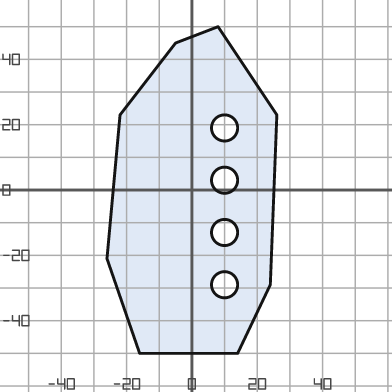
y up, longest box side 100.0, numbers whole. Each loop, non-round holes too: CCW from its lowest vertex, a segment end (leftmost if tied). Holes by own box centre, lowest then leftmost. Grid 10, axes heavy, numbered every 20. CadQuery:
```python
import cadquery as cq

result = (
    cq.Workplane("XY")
    .moveTo(-16.0, -50.0)
    .lineTo(14.0, -50.0)
    .lineTo(24.0, -29.0)
    .lineTo(26.0, 23.0)
    .lineTo(8.0, 50.0)
    .lineTo(-5.0, 45.0)
    .lineTo(-22.0, 23.0)
    .lineTo(-26.0, -21.0)
    .close()
    .moveTo(10.0, -29.0)
    .circle(4.0)
    .moveTo(10.0, -13.0)
    .circle(4.0)
    .moveTo(10.0, 3.0)
    .circle(4.0)
    .moveTo(10.0, 19.0)
    .circle(4.0)
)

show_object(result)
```